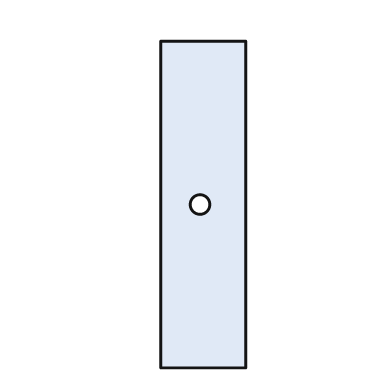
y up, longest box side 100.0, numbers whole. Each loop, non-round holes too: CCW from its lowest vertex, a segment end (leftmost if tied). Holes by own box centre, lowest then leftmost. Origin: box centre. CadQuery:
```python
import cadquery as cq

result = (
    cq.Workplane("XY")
    .moveTo(-13.0, -50.0)
    .lineTo(13.0, -50.0)
    .lineTo(13.0, 50.0)
    .lineTo(-13.0, 50.0)
    .close()
    .moveTo(-1.0, 0.0)
    .circle(3.0)
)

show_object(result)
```